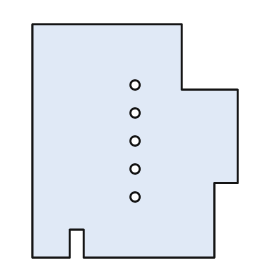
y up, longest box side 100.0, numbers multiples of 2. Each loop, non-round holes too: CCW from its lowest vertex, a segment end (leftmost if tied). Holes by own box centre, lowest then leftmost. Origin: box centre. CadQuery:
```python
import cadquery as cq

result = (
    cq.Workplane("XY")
    .moveTo(-44.0, -50.0)
    .lineTo(-28.0, -50.0)
    .lineTo(-28.0, -38.0)
    .lineTo(-22.0, -38.0)
    .lineTo(-22.0, -50.0)
    .lineTo(34.0, -50.0)
    .lineTo(34.0, -18.0)
    .lineTo(44.0, -18.0)
    .lineTo(44.0, 22.0)
    .lineTo(20.0, 22.0)
    .lineTo(20.0, 50.0)
    .lineTo(-44.0, 50.0)
    .close()
    .moveTo(0.0, -24.0)
    .circle(2.0)
    .moveTo(0.0, -12.0)
    .circle(2.0)
    .moveTo(0.0, 0.0)
    .circle(2.0)
    .moveTo(0.0, 12.0)
    .circle(2.0)
    .moveTo(0.0, 24.0)
    .circle(2.0)
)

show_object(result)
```